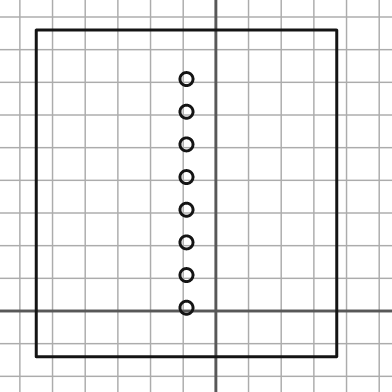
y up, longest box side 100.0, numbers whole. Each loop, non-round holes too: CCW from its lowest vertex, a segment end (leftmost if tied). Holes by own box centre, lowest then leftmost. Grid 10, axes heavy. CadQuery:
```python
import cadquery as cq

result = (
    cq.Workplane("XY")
    .moveTo(-55.0, -14.0)
    .lineTo(37.0, -14.0)
    .lineTo(37.0, 86.0)
    .lineTo(-55.0, 86.0)
    .close()
    .moveTo(-9.0, 1.0)
    .circle(2.0)
    .moveTo(-9.0, 11.0)
    .circle(2.0)
    .moveTo(-9.0, 21.0)
    .circle(2.0)
    .moveTo(-9.0, 31.0)
    .circle(2.0)
    .moveTo(-9.0, 41.0)
    .circle(2.0)
    .moveTo(-9.0, 51.0)
    .circle(2.0)
    .moveTo(-9.0, 61.0)
    .circle(2.0)
    .moveTo(-9.0, 71.0)
    .circle(2.0)
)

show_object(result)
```